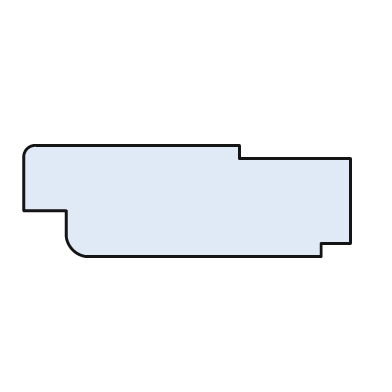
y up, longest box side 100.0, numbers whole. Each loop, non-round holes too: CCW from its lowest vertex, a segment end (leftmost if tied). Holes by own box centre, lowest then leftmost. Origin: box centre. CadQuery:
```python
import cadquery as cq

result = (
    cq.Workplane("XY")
    .moveTo(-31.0, -17.0)
    .lineTo(41.0, -17.0)
    .lineTo(41.0, -13.0)
    .lineTo(50.0, -13.0)
    .lineTo(50.0, 13.0)
    .lineTo(16.0, 13.0)
    .lineTo(16.0, 17.0)
    .lineTo(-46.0, 17.0)
    .threePointArc((-49.0, 16.0), (-50.0, 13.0))
    .lineTo(-50.0, -3.0)
    .lineTo(-37.0, -3.0)
    .lineTo(-37.0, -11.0)
    .threePointArc((-35.0, -15.0), (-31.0, -17.0))
    .close()
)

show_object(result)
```